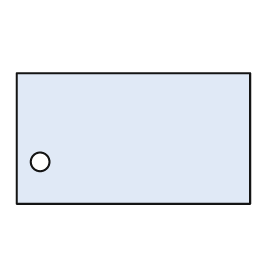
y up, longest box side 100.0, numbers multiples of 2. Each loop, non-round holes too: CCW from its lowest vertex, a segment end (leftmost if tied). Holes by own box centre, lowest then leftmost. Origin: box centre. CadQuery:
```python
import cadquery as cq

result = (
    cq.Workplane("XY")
    .moveTo(-50.0, -28.0)
    .lineTo(50.0, -28.0)
    .lineTo(50.0, 28.0)
    .lineTo(-50.0, 28.0)
    .close()
    .moveTo(-40.0, -10.0)
    .circle(4.0)
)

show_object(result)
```